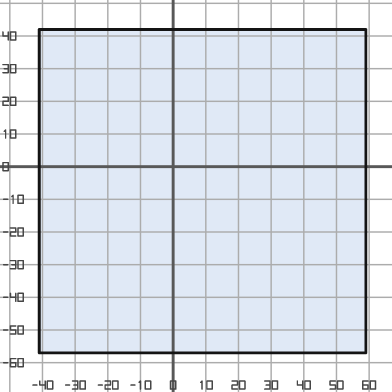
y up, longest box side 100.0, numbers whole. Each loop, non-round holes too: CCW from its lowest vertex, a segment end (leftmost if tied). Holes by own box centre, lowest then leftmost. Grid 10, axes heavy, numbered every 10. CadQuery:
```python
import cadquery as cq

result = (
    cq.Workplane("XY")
    .moveTo(-41.0, -57.0)
    .lineTo(59.0, -57.0)
    .lineTo(59.0, 42.0)
    .lineTo(-41.0, 42.0)
    .close()
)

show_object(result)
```